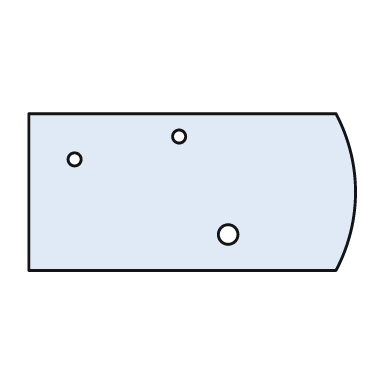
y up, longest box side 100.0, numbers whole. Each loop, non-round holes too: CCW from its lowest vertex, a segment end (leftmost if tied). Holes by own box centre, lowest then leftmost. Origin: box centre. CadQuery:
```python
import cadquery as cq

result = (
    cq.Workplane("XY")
    .moveTo(-50.0, -24.0)
    .lineTo(44.0, -24.0)
    .threePointArc((50.0, 0.0), (44.0, 24.0))
    .lineTo(-50.0, 24.0)
    .close()
    .moveTo(11.0, -13.0)
    .circle(3.0)
    .moveTo(-36.0, 10.0)
    .circle(2.0)
    .moveTo(-4.0, 17.0)
    .circle(2.0)
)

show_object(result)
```